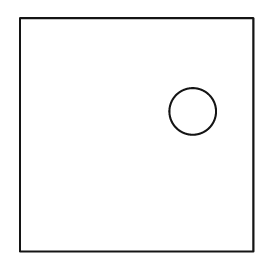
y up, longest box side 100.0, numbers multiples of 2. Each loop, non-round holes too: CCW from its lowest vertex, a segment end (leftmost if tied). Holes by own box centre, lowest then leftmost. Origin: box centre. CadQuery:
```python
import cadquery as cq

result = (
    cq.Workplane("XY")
    .moveTo(-50.0, -50.0)
    .lineTo(50.0, -50.0)
    .lineTo(50.0, 50.0)
    .lineTo(-50.0, 50.0)
    .close()
    .moveTo(24.0, 10.0)
    .circle(10.0)
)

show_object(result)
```